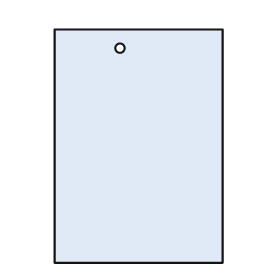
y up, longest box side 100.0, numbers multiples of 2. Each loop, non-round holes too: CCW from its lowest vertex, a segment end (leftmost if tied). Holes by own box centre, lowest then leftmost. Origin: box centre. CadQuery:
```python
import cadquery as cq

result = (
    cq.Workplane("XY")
    .moveTo(-36.0, -50.0)
    .lineTo(36.0, -50.0)
    .lineTo(36.0, 50.0)
    .lineTo(-36.0, 50.0)
    .close()
    .moveTo(-8.0, 42.0)
    .circle(2.0)
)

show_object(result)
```